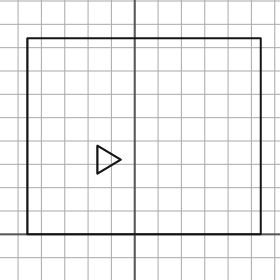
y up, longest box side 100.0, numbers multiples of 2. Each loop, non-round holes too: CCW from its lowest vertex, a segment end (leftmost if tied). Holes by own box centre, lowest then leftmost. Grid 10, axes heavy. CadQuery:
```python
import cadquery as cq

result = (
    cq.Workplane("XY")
    .moveTo(-46.0, 0.0)
    .lineTo(54.0, 0.0)
    .lineTo(54.0, 84.0)
    .lineTo(-46.0, 84.0)
    .close()
    .moveTo(-16.0, 26.0)
    .lineTo(-6.0, 32.0)
    .lineTo(-16.0, 38.0)
    .close()
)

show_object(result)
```